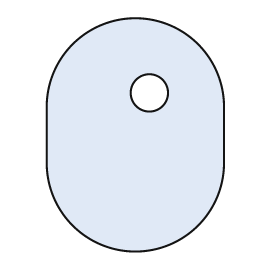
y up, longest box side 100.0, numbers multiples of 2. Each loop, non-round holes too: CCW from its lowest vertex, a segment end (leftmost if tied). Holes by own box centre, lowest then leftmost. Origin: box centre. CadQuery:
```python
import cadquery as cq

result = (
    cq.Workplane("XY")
    .moveTo(-38.0, -12.0)
    .threePointArc((0.0, -50.0), (38.0, -12.0))
    .lineTo(38.0, 12.0)
    .threePointArc((0.0, 50.0), (-38.0, 12.0))
    .close()
    .moveTo(6.0, 18.0)
    .circle(8.0)
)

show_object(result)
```